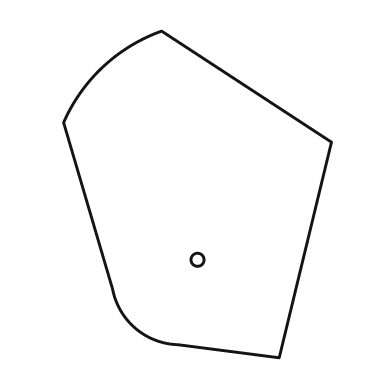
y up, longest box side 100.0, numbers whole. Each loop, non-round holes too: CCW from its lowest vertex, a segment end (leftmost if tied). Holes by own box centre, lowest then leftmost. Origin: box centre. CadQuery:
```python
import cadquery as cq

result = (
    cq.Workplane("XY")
    .moveTo(25.0, -50.0)
    .lineTo(41.0, 16.0)
    .lineTo(-11.0, 50.0)
    .threePointArc((-29.0, 39.0), (-41.0, 22.0))
    .lineTo(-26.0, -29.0)
    .threePointArc((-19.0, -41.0), (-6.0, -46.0))
    .close()
    .moveTo(0.0, -20.0)
    .circle(2.0)
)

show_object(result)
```